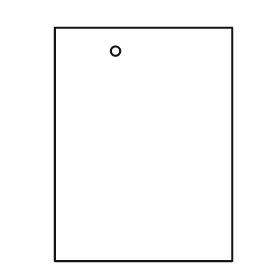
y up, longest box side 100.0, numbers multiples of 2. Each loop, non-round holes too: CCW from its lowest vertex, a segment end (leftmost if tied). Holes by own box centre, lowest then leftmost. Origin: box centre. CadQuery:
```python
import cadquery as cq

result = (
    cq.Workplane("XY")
    .moveTo(-38.0, -50.0)
    .lineTo(38.0, -50.0)
    .lineTo(38.0, 50.0)
    .lineTo(-38.0, 50.0)
    .close()
    .moveTo(-12.0, 40.0)
    .circle(2.0)
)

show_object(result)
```